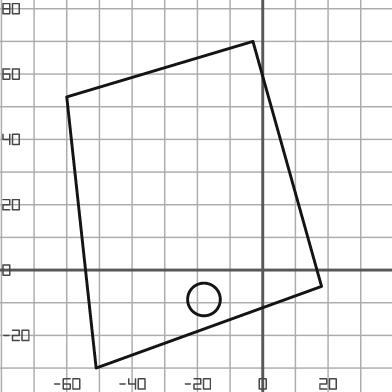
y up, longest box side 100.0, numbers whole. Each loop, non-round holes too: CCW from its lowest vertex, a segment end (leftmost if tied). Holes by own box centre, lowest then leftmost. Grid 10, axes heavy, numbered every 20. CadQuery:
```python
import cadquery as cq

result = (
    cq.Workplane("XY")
    .moveTo(-51.0, -30.0)
    .lineTo(18.0, -5.0)
    .lineTo(-3.0, 70.0)
    .lineTo(-60.0, 53.0)
    .close()
    .moveTo(-18.0, -9.0)
    .circle(5.0)
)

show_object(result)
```